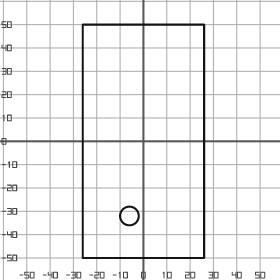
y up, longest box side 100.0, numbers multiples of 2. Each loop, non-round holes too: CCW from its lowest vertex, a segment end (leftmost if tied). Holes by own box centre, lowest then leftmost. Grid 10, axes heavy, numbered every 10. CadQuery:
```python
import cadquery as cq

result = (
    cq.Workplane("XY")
    .moveTo(-26.0, -50.0)
    .lineTo(26.0, -50.0)
    .lineTo(26.0, 50.0)
    .lineTo(-26.0, 50.0)
    .close()
    .moveTo(-6.0, -32.0)
    .circle(4.0)
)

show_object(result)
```